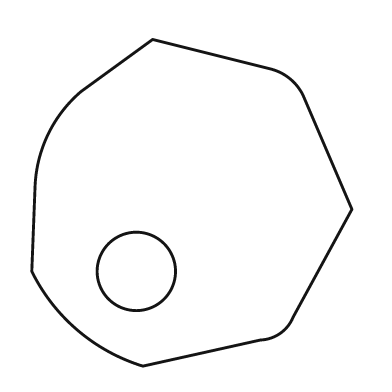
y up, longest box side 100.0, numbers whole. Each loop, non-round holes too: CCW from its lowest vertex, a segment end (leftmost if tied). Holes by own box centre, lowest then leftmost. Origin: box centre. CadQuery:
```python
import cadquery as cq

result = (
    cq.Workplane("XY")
    .moveTo(-15.0, -50.0)
    .lineTo(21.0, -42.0)
    .threePointArc((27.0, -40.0), (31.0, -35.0))
    .lineTo(49.0, -2.0)
    .lineTo(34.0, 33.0)
    .threePointArc((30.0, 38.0), (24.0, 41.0))
    .lineTo(-12.0, 50.0)
    .lineTo(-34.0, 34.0)
    .threePointArc((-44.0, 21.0), (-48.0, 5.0))
    .lineTo(-49.0, -21.0)
    .threePointArc((-35.0, -39.0), (-15.0, -50.0))
    .close()
    .moveTo(-17.0, -21.0)
    .circle(12.0)
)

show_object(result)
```